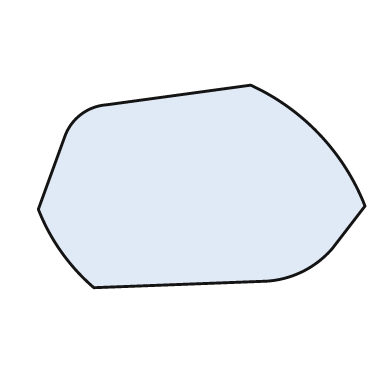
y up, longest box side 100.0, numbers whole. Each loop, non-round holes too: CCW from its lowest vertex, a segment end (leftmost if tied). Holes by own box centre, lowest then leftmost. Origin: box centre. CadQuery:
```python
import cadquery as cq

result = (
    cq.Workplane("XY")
    .moveTo(-33.0, -31.0)
    .lineTo(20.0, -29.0)
    .threePointArc((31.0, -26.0), (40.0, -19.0))
    .lineTo(50.0, -6.0)
    .threePointArc((36.0, 16.0), (15.0, 31.0))
    .lineTo(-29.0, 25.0)
    .threePointArc((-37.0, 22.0), (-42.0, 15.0))
    .lineTo(-50.0, -7.0)
    .threePointArc((-43.0, -20.0), (-33.0, -31.0))
    .close()
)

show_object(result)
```